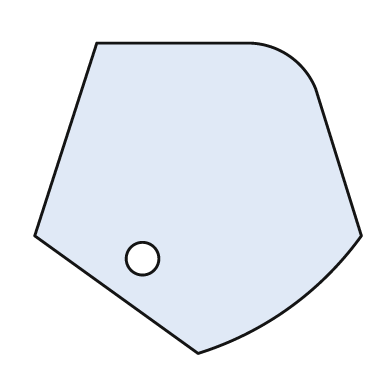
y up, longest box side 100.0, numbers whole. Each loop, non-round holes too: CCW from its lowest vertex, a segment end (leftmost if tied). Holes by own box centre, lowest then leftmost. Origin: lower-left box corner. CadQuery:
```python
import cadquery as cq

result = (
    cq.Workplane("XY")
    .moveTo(50.0, 0.0)
    .threePointArc((78.0, 14.0), (100.0, 36.0))
    .lineTo(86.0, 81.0)
    .threePointArc((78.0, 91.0), (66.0, 95.0))
    .lineTo(19.0, 95.0)
    .lineTo(0.0, 36.0)
    .close()
    .moveTo(33.0, 29.0)
    .circle(5.0)
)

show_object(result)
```